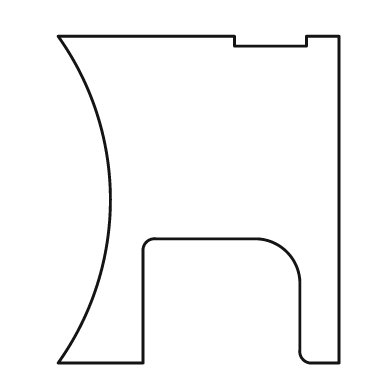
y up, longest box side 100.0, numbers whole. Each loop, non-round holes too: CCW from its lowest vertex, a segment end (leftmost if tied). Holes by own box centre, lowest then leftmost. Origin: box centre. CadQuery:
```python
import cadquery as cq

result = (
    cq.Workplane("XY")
    .moveTo(-43.0, -50.0)
    .lineTo(-17.0, -50.0)
    .lineTo(-17.0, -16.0)
    .threePointArc((-16.0, -13.0), (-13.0, -12.0))
    .lineTo(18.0, -12.0)
    .threePointArc((27.0, -16.0), (31.0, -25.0))
    .lineTo(31.0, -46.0)
    .threePointArc((32.0, -49.0), (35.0, -50.0))
    .lineTo(43.0, -50.0)
    .lineTo(43.0, 50.0)
    .lineTo(33.0, 50.0)
    .lineTo(33.0, 47.0)
    .lineTo(11.0, 47.0)
    .lineTo(11.0, 50.0)
    .lineTo(-43.0, 50.0)
    .threePointArc((-27.0, 0.0), (-43.0, -50.0))
    .close()
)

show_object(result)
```